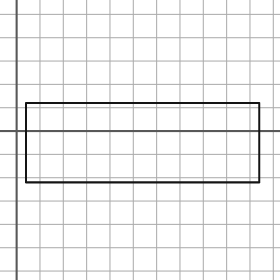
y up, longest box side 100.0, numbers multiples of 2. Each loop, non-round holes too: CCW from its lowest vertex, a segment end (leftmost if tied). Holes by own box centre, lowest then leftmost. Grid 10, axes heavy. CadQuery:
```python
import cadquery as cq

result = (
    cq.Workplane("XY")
    .moveTo(4.0, -22.0)
    .lineTo(104.0, -22.0)
    .lineTo(104.0, 12.0)
    .lineTo(4.0, 12.0)
    .close()
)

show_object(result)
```